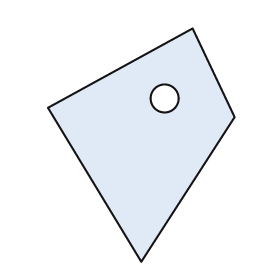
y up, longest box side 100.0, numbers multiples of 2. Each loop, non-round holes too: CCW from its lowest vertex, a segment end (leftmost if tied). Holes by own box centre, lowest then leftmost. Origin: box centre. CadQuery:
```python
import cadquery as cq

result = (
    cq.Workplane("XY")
    .moveTo(0.0, -50.0)
    .lineTo(40.0, 12.0)
    .lineTo(22.0, 50.0)
    .lineTo(-40.0, 16.0)
    .close()
    .moveTo(10.0, 20.0)
    .circle(6.0)
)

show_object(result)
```